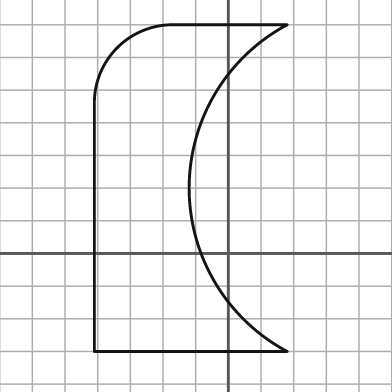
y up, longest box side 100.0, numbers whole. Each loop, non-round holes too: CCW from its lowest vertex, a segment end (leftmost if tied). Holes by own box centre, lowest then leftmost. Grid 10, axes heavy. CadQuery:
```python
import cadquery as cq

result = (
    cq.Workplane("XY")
    .moveTo(-41.0, -30.0)
    .lineTo(18.0, -30.0)
    .threePointArc((-12.0, 20.0), (18.0, 70.0))
    .lineTo(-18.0, 70.0)
    .threePointArc((-34.0, 63.0), (-41.0, 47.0))
    .close()
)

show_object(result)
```